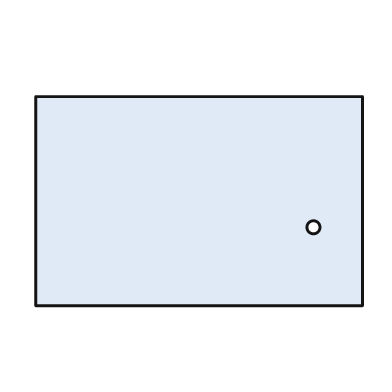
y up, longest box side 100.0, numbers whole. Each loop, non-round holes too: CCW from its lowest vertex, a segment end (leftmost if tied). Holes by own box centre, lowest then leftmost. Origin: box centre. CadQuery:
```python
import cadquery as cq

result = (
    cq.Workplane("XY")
    .moveTo(-50.0, -32.0)
    .lineTo(50.0, -32.0)
    .lineTo(50.0, 32.0)
    .lineTo(-50.0, 32.0)
    .close()
    .moveTo(35.0, -8.0)
    .circle(2.0)
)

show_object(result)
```